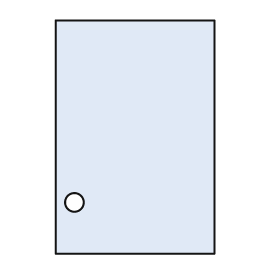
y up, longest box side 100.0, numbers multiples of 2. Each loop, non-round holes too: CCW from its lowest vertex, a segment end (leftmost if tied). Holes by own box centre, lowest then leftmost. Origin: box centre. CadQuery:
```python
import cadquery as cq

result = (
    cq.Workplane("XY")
    .moveTo(-34.0, -50.0)
    .lineTo(34.0, -50.0)
    .lineTo(34.0, 50.0)
    .lineTo(-34.0, 50.0)
    .close()
    .moveTo(-26.0, -28.0)
    .circle(4.0)
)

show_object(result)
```